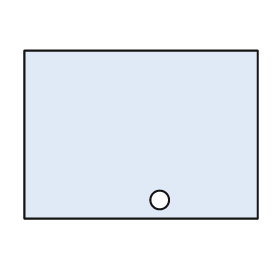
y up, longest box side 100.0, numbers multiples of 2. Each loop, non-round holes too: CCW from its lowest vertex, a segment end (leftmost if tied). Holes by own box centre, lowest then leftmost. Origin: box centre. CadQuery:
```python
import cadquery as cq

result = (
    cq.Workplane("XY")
    .moveTo(-50.0, -36.0)
    .lineTo(50.0, -36.0)
    .lineTo(50.0, 36.0)
    .lineTo(-50.0, 36.0)
    .close()
    .moveTo(8.0, -28.0)
    .circle(4.0)
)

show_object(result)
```